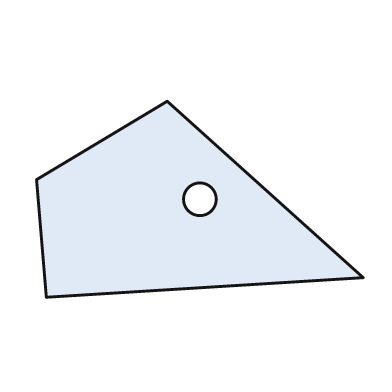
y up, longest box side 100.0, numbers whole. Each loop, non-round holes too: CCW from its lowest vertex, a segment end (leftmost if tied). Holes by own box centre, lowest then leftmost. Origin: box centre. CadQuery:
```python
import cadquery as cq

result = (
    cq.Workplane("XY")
    .moveTo(-47.0, -30.0)
    .lineTo(50.0, -24.0)
    .lineTo(-10.0, 30.0)
    .lineTo(-50.0, 6.0)
    .close()
    .moveTo(0.0, 0.0)
    .circle(5.0)
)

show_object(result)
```